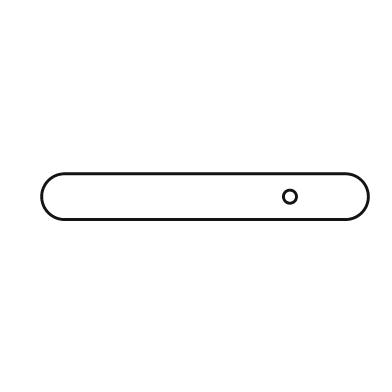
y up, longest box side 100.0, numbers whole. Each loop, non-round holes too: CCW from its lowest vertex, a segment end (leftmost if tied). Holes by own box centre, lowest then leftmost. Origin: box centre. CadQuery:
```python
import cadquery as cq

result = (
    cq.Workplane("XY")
    .moveTo(-43.0, -7.0)
    .lineTo(43.0, -7.0)
    .threePointArc((50.0, 0.0), (43.0, 7.0))
    .lineTo(-43.0, 7.0)
    .threePointArc((-50.0, 0.0), (-43.0, -7.0))
    .close()
    .moveTo(26.0, 0.0)
    .circle(2.0)
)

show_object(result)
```